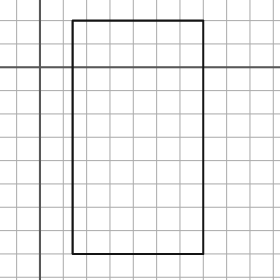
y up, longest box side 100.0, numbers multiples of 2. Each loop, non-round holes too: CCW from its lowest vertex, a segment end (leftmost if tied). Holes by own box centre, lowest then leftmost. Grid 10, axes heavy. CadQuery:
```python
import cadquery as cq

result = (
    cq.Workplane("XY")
    .moveTo(14.0, -80.0)
    .lineTo(70.0, -80.0)
    .lineTo(70.0, 20.0)
    .lineTo(14.0, 20.0)
    .close()
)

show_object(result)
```